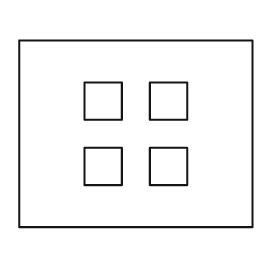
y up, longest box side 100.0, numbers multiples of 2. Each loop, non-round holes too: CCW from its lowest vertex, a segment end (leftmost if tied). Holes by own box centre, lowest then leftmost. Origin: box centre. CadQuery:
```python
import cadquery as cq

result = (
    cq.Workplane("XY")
    .moveTo(-50.0, -40.0)
    .lineTo(50.0, -40.0)
    .lineTo(50.0, 40.0)
    .lineTo(-50.0, 40.0)
    .close()
    .moveTo(-22.0, -22.0)
    .lineTo(-6.0, -22.0)
    .lineTo(-6.0, -6.0)
    .lineTo(-22.0, -6.0)
    .close()
    .moveTo(6.0, -22.0)
    .lineTo(22.0, -22.0)
    .lineTo(22.0, -6.0)
    .lineTo(6.0, -6.0)
    .close()
    .moveTo(-22.0, 6.0)
    .lineTo(-6.0, 6.0)
    .lineTo(-6.0, 22.0)
    .lineTo(-22.0, 22.0)
    .close()
    .moveTo(6.0, 6.0)
    .lineTo(22.0, 6.0)
    .lineTo(22.0, 22.0)
    .lineTo(6.0, 22.0)
    .close()
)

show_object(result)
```